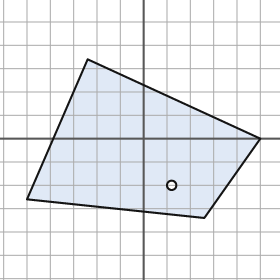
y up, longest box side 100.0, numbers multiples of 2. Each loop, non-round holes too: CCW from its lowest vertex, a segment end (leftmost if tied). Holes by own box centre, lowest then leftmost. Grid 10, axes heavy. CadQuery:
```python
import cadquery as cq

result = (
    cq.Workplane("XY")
    .moveTo(26.0, -34.0)
    .lineTo(50.0, 0.0)
    .lineTo(-24.0, 34.0)
    .lineTo(-50.0, -26.0)
    .close()
    .moveTo(12.0, -20.0)
    .circle(2.0)
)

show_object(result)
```